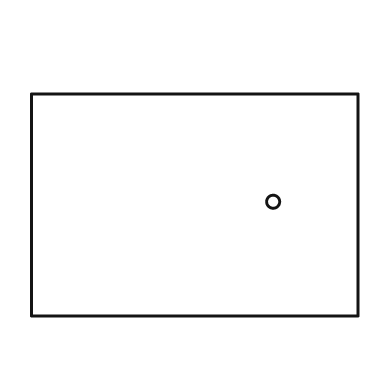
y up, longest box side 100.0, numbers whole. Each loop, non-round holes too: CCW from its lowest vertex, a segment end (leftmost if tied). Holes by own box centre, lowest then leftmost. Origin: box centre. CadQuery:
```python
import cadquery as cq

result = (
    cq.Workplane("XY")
    .moveTo(-50.0, -34.0)
    .lineTo(50.0, -34.0)
    .lineTo(50.0, 34.0)
    .lineTo(-50.0, 34.0)
    .close()
    .moveTo(24.0, 1.0)
    .circle(2.0)
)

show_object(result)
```